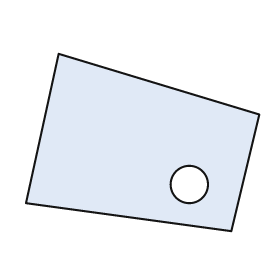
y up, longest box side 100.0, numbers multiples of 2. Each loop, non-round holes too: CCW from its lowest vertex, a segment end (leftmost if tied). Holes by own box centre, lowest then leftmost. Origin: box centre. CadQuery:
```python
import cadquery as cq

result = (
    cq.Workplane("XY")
    .moveTo(38.0, -38.0)
    .lineTo(50.0, 12.0)
    .lineTo(-36.0, 38.0)
    .lineTo(-50.0, -26.0)
    .close()
    .moveTo(20.0, -18.0)
    .circle(8.0)
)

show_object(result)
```